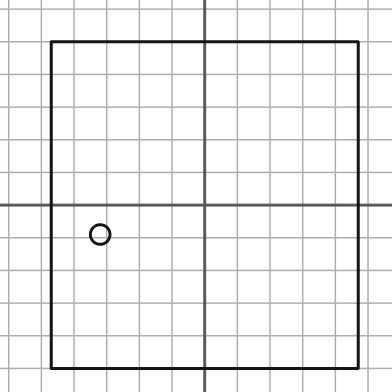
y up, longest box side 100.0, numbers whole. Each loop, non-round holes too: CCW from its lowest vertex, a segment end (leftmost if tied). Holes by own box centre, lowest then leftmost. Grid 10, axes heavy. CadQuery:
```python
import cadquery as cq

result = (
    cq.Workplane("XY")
    .moveTo(-47.0, -50.0)
    .lineTo(47.0, -50.0)
    .lineTo(47.0, 50.0)
    .lineTo(-47.0, 50.0)
    .close()
    .moveTo(-32.0, -9.0)
    .circle(3.0)
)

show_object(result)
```